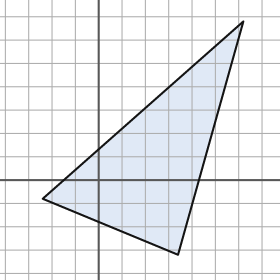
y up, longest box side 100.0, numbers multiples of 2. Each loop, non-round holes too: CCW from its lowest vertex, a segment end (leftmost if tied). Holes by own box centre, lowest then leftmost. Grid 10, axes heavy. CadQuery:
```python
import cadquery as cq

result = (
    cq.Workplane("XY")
    .moveTo(34.0, -32.0)
    .lineTo(62.0, 68.0)
    .lineTo(-24.0, -8.0)
    .close()
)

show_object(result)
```